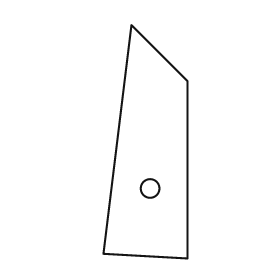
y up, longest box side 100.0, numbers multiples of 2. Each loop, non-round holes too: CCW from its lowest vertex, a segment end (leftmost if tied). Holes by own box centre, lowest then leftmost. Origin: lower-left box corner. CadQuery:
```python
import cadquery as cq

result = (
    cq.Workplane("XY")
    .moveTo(36.0, 0.0)
    .lineTo(36.0, 76.0)
    .lineTo(12.0, 100.0)
    .lineTo(0.0, 2.0)
    .close()
    .moveTo(20.0, 30.0)
    .circle(4.0)
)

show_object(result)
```